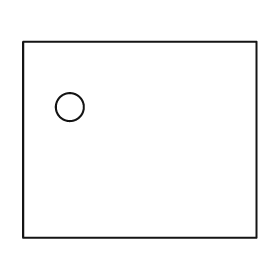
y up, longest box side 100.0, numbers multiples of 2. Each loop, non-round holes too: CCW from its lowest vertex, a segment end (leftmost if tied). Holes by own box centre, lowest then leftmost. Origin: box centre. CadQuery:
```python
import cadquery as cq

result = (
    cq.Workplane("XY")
    .moveTo(-50.0, -42.0)
    .lineTo(50.0, -42.0)
    .lineTo(50.0, 42.0)
    .lineTo(-50.0, 42.0)
    .close()
    .moveTo(-30.0, 14.0)
    .circle(6.0)
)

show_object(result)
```